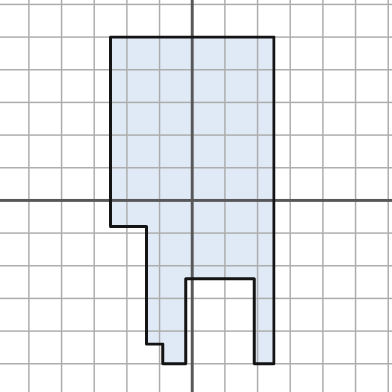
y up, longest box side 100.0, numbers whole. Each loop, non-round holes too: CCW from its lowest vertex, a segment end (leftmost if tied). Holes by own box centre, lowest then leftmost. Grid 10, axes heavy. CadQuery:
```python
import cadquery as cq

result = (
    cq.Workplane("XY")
    .moveTo(-9.0, -50.0)
    .lineTo(-2.0, -50.0)
    .lineTo(-2.0, -24.0)
    .lineTo(19.0, -24.0)
    .lineTo(19.0, -50.0)
    .lineTo(25.0, -50.0)
    .lineTo(25.0, 50.0)
    .lineTo(-25.0, 50.0)
    .lineTo(-25.0, -8.0)
    .lineTo(-14.0, -8.0)
    .lineTo(-14.0, -44.0)
    .lineTo(-9.0, -44.0)
    .close()
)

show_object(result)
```